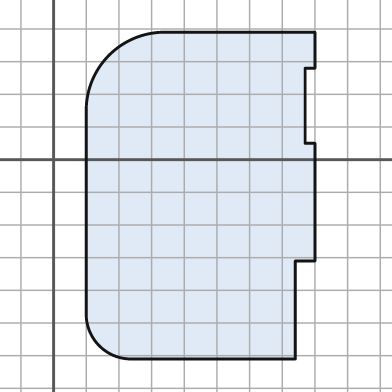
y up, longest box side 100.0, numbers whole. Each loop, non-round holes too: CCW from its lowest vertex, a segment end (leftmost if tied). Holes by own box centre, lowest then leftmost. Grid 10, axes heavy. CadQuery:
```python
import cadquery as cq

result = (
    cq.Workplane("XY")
    .moveTo(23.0, -61.0)
    .lineTo(74.0, -61.0)
    .lineTo(74.0, -31.0)
    .lineTo(80.0, -31.0)
    .lineTo(80.0, 5.0)
    .lineTo(77.0, 5.0)
    .lineTo(77.0, 28.0)
    .lineTo(80.0, 28.0)
    .lineTo(80.0, 39.0)
    .lineTo(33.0, 39.0)
    .threePointArc((17.0, 32.0), (10.0, 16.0))
    .lineTo(10.0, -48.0)
    .threePointArc((14.0, -57.0), (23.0, -61.0))
    .close()
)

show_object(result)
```